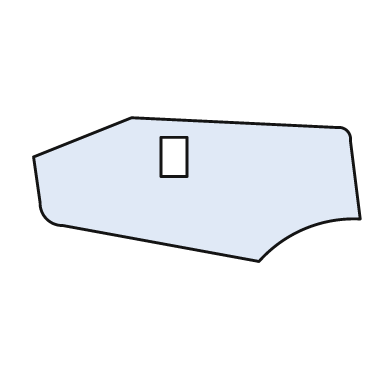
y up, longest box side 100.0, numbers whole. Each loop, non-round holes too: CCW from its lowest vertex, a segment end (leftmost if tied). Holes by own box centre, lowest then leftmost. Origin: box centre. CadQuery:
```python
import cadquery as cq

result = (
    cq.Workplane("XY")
    .moveTo(19.0, -22.0)
    .threePointArc((33.0, -12.0), (50.0, -9.0))
    .lineTo(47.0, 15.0)
    .threePointArc((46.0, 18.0), (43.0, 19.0))
    .lineTo(-20.0, 22.0)
    .lineTo(-50.0, 10.0)
    .lineTo(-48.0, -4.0)
    .threePointArc((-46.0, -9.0), (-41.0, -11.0))
    .close()
    .moveTo(-11.0, 4.0)
    .lineTo(-3.0, 4.0)
    .lineTo(-3.0, 16.0)
    .lineTo(-11.0, 16.0)
    .close()
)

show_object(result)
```